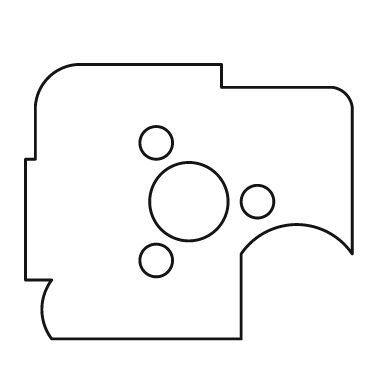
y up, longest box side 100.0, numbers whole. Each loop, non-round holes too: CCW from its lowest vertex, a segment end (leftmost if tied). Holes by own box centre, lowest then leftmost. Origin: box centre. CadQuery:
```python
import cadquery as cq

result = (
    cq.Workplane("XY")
    .moveTo(-42.0, -42.0)
    .lineTo(16.0, -42.0)
    .lineTo(16.0, -16.0)
    .threePointArc((33.0, -7.0), (50.0, -16.0))
    .lineTo(50.0, 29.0)
    .threePointArc((48.0, 33.0), (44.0, 35.0))
    .lineTo(10.0, 35.0)
    .lineTo(10.0, 42.0)
    .lineTo(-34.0, 42.0)
    .threePointArc((-43.0, 38.0), (-47.0, 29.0))
    .lineTo(-47.0, 13.0)
    .lineTo(-50.0, 13.0)
    .lineTo(-50.0, -24.0)
    .lineTo(-42.0, -24.0)
    .threePointArc((-45.0, -33.0), (-42.0, -42.0))
    .close()
    .moveTo(-10.0, -18.0)
    .circle(5.0)
    .moveTo(0.0, 0.0)
    .circle(12.0)
    .moveTo(21.0, 0.0)
    .circle(5.0)
    .moveTo(-10.0, 18.0)
    .circle(5.0)
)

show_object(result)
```